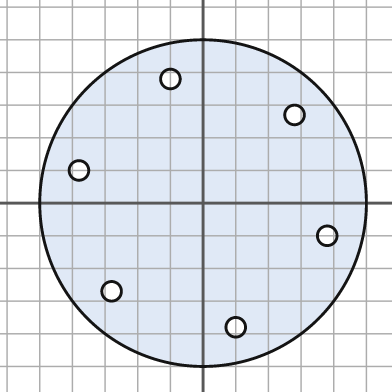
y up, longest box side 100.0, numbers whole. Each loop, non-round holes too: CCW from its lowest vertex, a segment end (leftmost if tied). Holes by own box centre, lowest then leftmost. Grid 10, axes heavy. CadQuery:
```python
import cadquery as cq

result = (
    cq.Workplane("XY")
    .moveTo(0.0, 0.0)
    .circle(50.0)
    .moveTo(10.0, -38.0)
    .circle(3.0)
    .moveTo(-28.0, -27.0)
    .circle(3.0)
    .moveTo(38.0, -10.0)
    .circle(3.0)
    .moveTo(-38.0, 10.0)
    .circle(3.0)
    .moveTo(28.0, 27.0)
    .circle(3.0)
    .moveTo(-10.0, 38.0)
    .circle(3.0)
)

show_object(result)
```